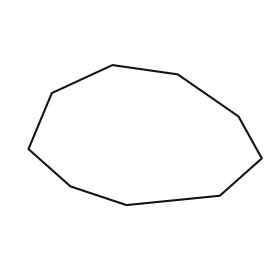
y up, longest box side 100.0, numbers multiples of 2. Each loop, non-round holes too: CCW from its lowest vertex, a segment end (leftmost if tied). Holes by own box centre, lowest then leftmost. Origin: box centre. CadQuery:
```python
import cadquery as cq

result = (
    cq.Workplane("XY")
    .moveTo(-8.0, -30.0)
    .lineTo(32.0, -26.0)
    .lineTo(50.0, -10.0)
    .lineTo(40.0, 8.0)
    .lineTo(14.0, 26.0)
    .lineTo(-14.0, 30.0)
    .lineTo(-40.0, 18.0)
    .lineTo(-50.0, -6.0)
    .lineTo(-32.0, -22.0)
    .close()
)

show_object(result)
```